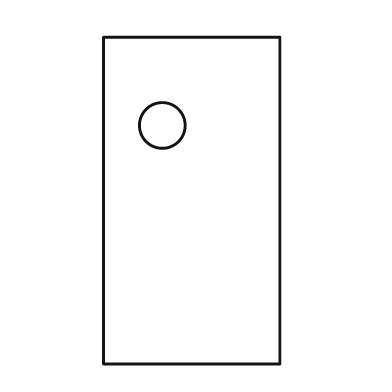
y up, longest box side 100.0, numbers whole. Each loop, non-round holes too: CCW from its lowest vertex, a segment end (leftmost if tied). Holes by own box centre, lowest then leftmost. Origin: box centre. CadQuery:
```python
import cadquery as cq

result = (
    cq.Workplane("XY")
    .moveTo(-27.0, -50.0)
    .lineTo(27.0, -50.0)
    .lineTo(27.0, 50.0)
    .lineTo(-27.0, 50.0)
    .close()
    .moveTo(-9.0, 23.0)
    .circle(7.0)
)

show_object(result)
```